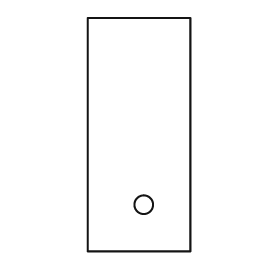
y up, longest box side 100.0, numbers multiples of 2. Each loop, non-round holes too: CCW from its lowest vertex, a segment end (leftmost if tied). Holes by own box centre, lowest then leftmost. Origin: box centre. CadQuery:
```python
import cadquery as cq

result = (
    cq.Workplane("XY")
    .moveTo(-22.0, -50.0)
    .lineTo(22.0, -50.0)
    .lineTo(22.0, 50.0)
    .lineTo(-22.0, 50.0)
    .close()
    .moveTo(2.0, -30.0)
    .circle(4.0)
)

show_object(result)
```